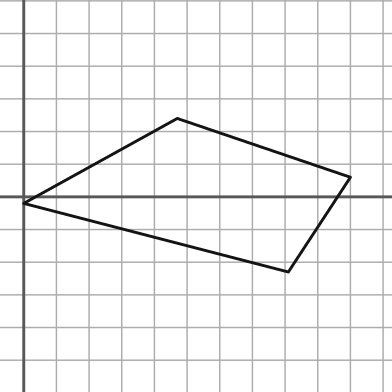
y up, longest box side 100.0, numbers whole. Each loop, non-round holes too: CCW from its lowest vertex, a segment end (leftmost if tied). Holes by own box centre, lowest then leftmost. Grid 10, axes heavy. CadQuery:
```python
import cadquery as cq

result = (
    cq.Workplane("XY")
    .moveTo(81.0, -23.0)
    .lineTo(100.0, 6.0)
    .lineTo(47.0, 24.0)
    .lineTo(0.0, -2.0)
    .close()
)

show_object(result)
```